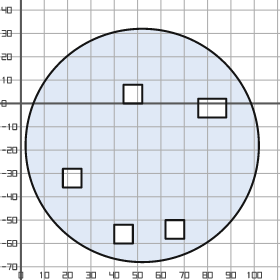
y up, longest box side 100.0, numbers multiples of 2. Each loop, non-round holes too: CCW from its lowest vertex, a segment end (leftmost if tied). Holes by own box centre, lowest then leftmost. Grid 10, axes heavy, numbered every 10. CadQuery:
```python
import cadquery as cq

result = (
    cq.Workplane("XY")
    .moveTo(52.0, -18.0)
    .circle(50.0)
    .moveTo(40.0, -60.0)
    .lineTo(48.0, -60.0)
    .lineTo(48.0, -52.0)
    .lineTo(40.0, -52.0)
    .close()
    .moveTo(62.0, -58.0)
    .lineTo(70.0, -58.0)
    .lineTo(70.0, -50.0)
    .lineTo(62.0, -50.0)
    .close()
    .moveTo(18.0, -36.0)
    .lineTo(26.0, -36.0)
    .lineTo(26.0, -28.0)
    .lineTo(18.0, -28.0)
    .close()
    .moveTo(76.0, -6.0)
    .lineTo(88.0, -6.0)
    .lineTo(88.0, 2.0)
    .lineTo(76.0, 2.0)
    .close()
    .moveTo(44.0, 0.0)
    .lineTo(52.0, 0.0)
    .lineTo(52.0, 8.0)
    .lineTo(44.0, 8.0)
    .close()
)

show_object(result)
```